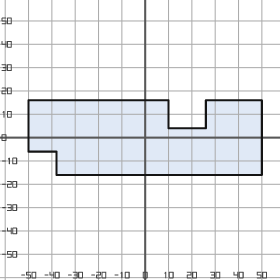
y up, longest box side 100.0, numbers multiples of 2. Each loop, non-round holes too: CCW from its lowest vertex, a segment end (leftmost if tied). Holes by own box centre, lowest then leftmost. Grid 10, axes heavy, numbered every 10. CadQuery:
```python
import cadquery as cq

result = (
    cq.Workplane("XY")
    .moveTo(-38.0, -16.0)
    .lineTo(50.0, -16.0)
    .lineTo(50.0, 16.0)
    .lineTo(26.0, 16.0)
    .lineTo(26.0, 4.0)
    .lineTo(10.0, 4.0)
    .lineTo(10.0, 16.0)
    .lineTo(-50.0, 16.0)
    .lineTo(-50.0, -6.0)
    .lineTo(-38.0, -6.0)
    .close()
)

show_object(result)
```